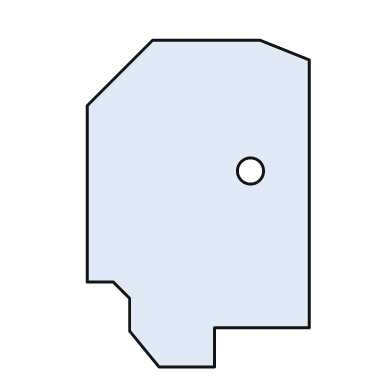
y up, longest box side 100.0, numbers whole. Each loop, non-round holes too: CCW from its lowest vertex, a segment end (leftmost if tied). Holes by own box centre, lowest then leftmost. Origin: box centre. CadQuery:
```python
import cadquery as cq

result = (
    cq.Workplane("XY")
    .moveTo(-12.0, -50.0)
    .lineTo(5.0, -50.0)
    .lineTo(5.0, -38.0)
    .lineTo(34.0, -38.0)
    .lineTo(34.0, 44.0)
    .lineTo(19.0, 50.0)
    .lineTo(-14.0, 50.0)
    .lineTo(-34.0, 30.0)
    .lineTo(-34.0, -24.0)
    .lineTo(-26.0, -24.0)
    .lineTo(-21.0, -29.0)
    .lineTo(-21.0, -39.0)
    .close()
    .moveTo(16.0, 10.0)
    .circle(4.0)
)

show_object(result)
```